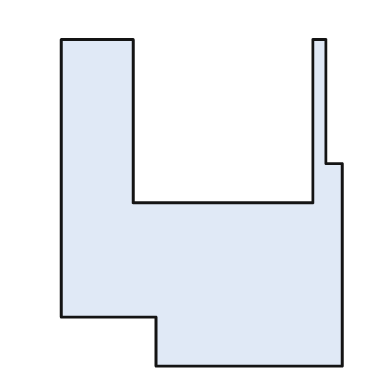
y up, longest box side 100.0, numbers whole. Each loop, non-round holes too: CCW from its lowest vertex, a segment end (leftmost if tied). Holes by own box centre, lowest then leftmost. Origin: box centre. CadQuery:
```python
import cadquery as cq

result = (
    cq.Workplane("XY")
    .moveTo(-14.0, -50.0)
    .lineTo(43.0, -50.0)
    .lineTo(43.0, 12.0)
    .lineTo(38.0, 12.0)
    .lineTo(38.0, 50.0)
    .lineTo(34.0, 50.0)
    .lineTo(34.0, 0.0)
    .lineTo(-21.0, 0.0)
    .lineTo(-21.0, 50.0)
    .lineTo(-43.0, 50.0)
    .lineTo(-43.0, -35.0)
    .lineTo(-14.0, -35.0)
    .close()
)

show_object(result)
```